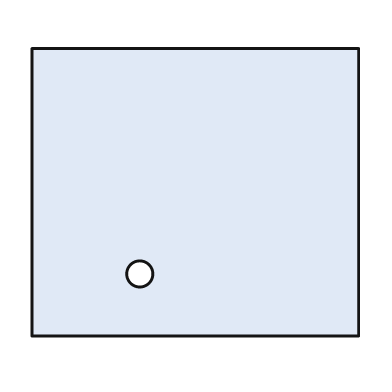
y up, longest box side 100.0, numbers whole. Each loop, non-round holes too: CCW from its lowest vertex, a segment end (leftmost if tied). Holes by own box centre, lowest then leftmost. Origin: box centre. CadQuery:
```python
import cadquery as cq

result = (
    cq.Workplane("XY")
    .moveTo(-50.0, -44.0)
    .lineTo(50.0, -44.0)
    .lineTo(50.0, 44.0)
    .lineTo(-50.0, 44.0)
    .close()
    .moveTo(-17.0, -25.0)
    .circle(4.0)
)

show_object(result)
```